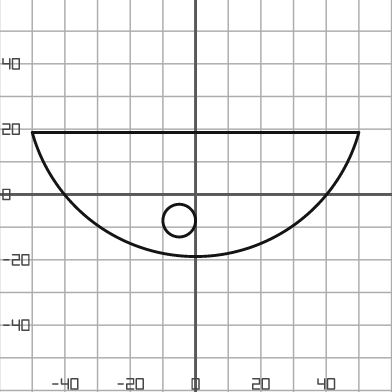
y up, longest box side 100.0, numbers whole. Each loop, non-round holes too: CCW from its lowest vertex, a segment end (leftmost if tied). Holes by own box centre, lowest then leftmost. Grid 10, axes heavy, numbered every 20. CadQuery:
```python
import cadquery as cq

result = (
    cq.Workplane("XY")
    .moveTo(-50.0, 19.0)
    .threePointArc((0.0, -19.0), (50.0, 19.0))
    .close()
    .moveTo(-5.0, -8.0)
    .circle(5.0)
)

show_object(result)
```